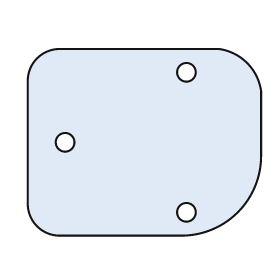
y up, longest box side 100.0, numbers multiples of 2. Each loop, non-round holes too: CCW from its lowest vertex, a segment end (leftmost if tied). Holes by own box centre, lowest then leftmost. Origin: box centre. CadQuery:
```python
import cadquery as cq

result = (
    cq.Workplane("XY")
    .moveTo(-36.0, -40.0)
    .lineTo(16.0, -40.0)
    .threePointArc((40.0, -30.0), (50.0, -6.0))
    .lineTo(50.0, 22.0)
    .threePointArc((44.0, 34.0), (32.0, 40.0))
    .lineTo(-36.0, 40.0)
    .threePointArc((-46.0, 36.0), (-50.0, 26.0))
    .lineTo(-50.0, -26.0)
    .threePointArc((-46.0, -36.0), (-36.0, -40.0))
    .close()
    .moveTo(18.0, -30.0)
    .circle(4.0)
    .moveTo(-34.0, 0.0)
    .circle(4.0)
    .moveTo(18.0, 30.0)
    .circle(4.0)
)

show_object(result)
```